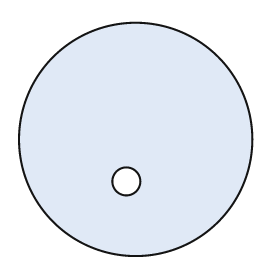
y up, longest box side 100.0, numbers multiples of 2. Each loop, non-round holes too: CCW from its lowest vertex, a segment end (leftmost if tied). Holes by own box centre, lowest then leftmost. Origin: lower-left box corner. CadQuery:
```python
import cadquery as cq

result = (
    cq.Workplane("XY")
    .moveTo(50.0, 50.0)
    .circle(50.0)
    .moveTo(46.0, 32.0)
    .circle(6.0)
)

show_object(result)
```